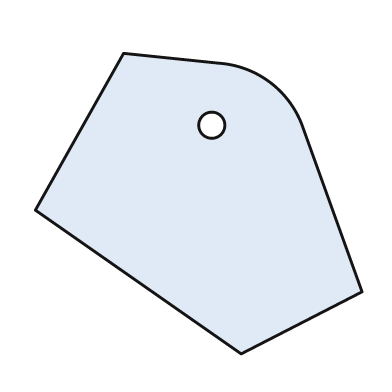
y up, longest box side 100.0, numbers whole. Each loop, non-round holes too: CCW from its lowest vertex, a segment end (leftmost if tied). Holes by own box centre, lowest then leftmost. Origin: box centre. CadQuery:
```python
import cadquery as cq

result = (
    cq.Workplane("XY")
    .moveTo(13.0, -46.0)
    .lineTo(50.0, -27.0)
    .lineTo(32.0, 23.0)
    .threePointArc((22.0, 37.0), (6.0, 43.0))
    .lineTo(-23.0, 46.0)
    .lineTo(-50.0, -2.0)
    .close()
    .moveTo(4.0, 24.0)
    .circle(4.0)
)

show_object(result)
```